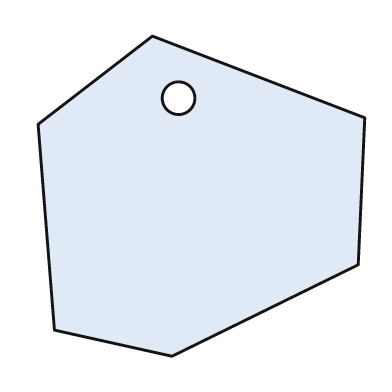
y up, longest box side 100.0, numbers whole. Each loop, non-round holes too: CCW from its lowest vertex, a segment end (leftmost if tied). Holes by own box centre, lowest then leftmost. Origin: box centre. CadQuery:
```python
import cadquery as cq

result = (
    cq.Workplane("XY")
    .moveTo(-9.0, -49.0)
    .lineTo(48.0, -21.0)
    .lineTo(50.0, 24.0)
    .lineTo(-15.0, 49.0)
    .lineTo(-50.0, 22.0)
    .lineTo(-45.0, -41.0)
    .close()
    .moveTo(-7.0, 30.0)
    .circle(5.0)
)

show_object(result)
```